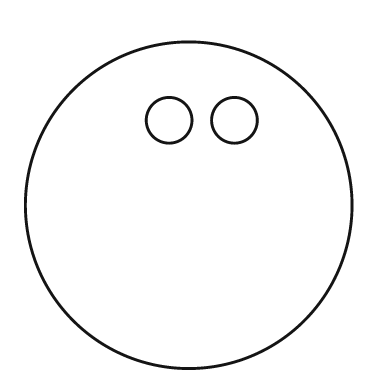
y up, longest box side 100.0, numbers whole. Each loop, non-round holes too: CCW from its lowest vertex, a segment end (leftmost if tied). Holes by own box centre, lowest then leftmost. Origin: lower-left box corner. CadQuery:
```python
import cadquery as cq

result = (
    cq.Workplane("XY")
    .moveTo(50.0, 50.0)
    .circle(50.0)
    .moveTo(44.0, 76.0)
    .circle(7.0)
    .moveTo(64.0, 76.0)
    .circle(7.0)
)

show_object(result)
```